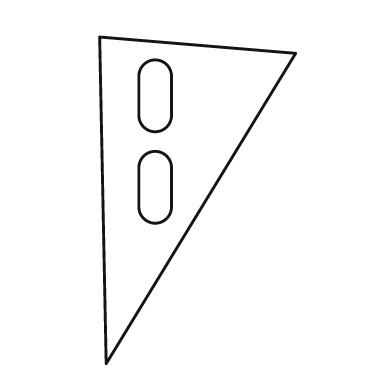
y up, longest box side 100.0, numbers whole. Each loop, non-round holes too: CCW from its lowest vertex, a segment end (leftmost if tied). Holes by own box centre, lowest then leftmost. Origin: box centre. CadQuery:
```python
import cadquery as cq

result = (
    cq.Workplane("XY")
    .moveTo(-28.0, -50.0)
    .lineTo(30.0, 45.0)
    .lineTo(-30.0, 50.0)
    .close()
    .moveTo(-18.0, -2.0)
    .threePointArc((-13.0, -7.0), (-8.0, -2.0))
    .lineTo(-8.0, 10.0)
    .threePointArc((-13.0, 15.0), (-18.0, 10.0))
    .close()
    .moveTo(-18.0, 26.0)
    .threePointArc((-13.0, 21.0), (-8.0, 26.0))
    .lineTo(-8.0, 38.0)
    .threePointArc((-13.0, 43.0), (-18.0, 38.0))
    .close()
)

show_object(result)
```